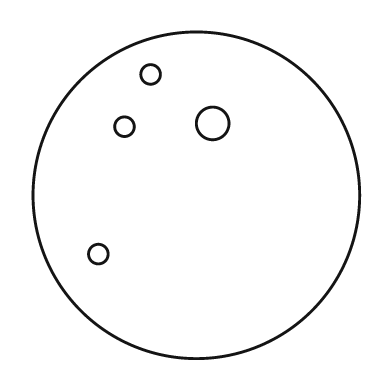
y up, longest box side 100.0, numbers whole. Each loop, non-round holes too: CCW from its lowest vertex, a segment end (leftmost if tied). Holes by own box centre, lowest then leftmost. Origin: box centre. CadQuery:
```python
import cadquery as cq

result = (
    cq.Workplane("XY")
    .moveTo(0.0, 0.0)
    .circle(50.0)
    .moveTo(-30.0, -18.0)
    .circle(3.0)
    .moveTo(-22.0, 21.0)
    .circle(3.0)
    .moveTo(5.0, 22.0)
    .circle(5.0)
    .moveTo(-14.0, 37.0)
    .circle(3.0)
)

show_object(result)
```